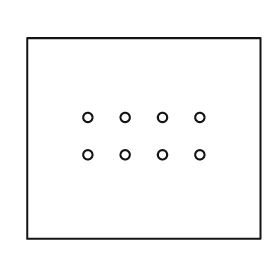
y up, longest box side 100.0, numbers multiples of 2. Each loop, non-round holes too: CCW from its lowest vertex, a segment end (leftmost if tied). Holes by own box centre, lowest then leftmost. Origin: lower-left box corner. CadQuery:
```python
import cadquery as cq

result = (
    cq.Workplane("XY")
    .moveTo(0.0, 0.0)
    .lineTo(100.0, 0.0)
    .lineTo(100.0, 86.0)
    .lineTo(0.0, 86.0)
    .close()
    .moveTo(26.0, 36.0)
    .circle(2.0)
    .moveTo(42.0, 36.0)
    .circle(2.0)
    .moveTo(58.0, 36.0)
    .circle(2.0)
    .moveTo(74.0, 36.0)
    .circle(2.0)
    .moveTo(26.0, 52.0)
    .circle(2.0)
    .moveTo(42.0, 52.0)
    .circle(2.0)
    .moveTo(58.0, 52.0)
    .circle(2.0)
    .moveTo(74.0, 52.0)
    .circle(2.0)
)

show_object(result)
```